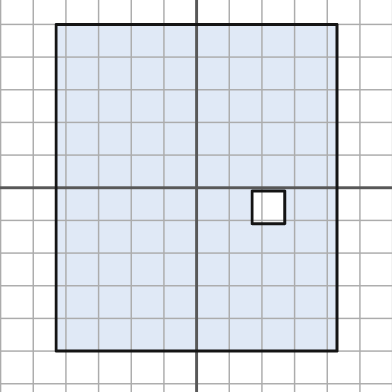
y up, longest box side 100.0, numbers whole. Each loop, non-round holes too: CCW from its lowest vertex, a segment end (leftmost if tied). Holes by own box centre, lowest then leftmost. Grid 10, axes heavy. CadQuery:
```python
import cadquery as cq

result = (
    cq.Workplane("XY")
    .moveTo(-43.0, -50.0)
    .lineTo(43.0, -50.0)
    .lineTo(43.0, 50.0)
    .lineTo(-43.0, 50.0)
    .close()
    .moveTo(17.0, -11.0)
    .lineTo(27.0, -11.0)
    .lineTo(27.0, -1.0)
    .lineTo(17.0, -1.0)
    .close()
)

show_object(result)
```